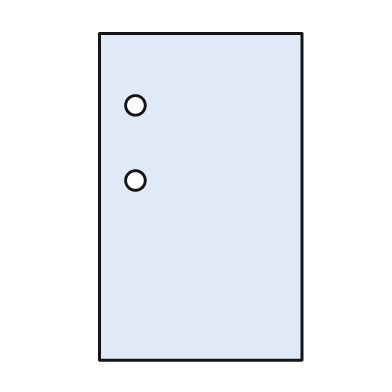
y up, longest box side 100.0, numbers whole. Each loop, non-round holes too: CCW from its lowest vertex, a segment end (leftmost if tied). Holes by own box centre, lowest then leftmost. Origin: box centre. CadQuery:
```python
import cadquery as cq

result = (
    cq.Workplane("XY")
    .moveTo(-31.0, -50.0)
    .lineTo(31.0, -50.0)
    .lineTo(31.0, 50.0)
    .lineTo(-31.0, 50.0)
    .close()
    .moveTo(-20.0, 5.0)
    .circle(3.0)
    .moveTo(-20.0, 28.0)
    .circle(3.0)
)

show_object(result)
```